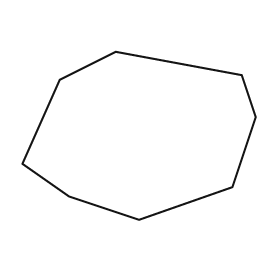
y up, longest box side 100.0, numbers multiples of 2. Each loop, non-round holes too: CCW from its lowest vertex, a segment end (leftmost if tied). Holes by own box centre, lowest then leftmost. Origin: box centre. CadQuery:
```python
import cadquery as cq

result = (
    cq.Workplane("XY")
    .moveTo(0.0, -36.0)
    .lineTo(40.0, -22.0)
    .lineTo(50.0, 8.0)
    .lineTo(44.0, 26.0)
    .lineTo(-10.0, 36.0)
    .lineTo(-34.0, 24.0)
    .lineTo(-50.0, -12.0)
    .lineTo(-30.0, -26.0)
    .close()
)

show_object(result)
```